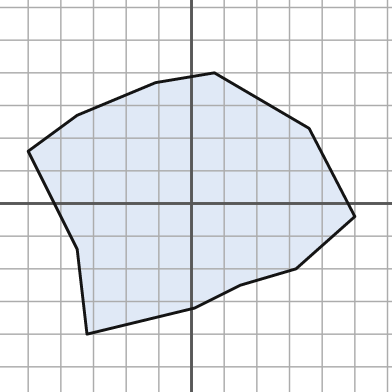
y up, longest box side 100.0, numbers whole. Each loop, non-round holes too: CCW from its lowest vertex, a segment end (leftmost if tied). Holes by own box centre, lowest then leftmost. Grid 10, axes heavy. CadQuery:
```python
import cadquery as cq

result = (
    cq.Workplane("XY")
    .moveTo(-32.0, -40.0)
    .lineTo(1.0, -32.0)
    .lineTo(15.0, -25.0)
    .lineTo(32.0, -20.0)
    .lineTo(50.0, -4.0)
    .lineTo(36.0, 23.0)
    .lineTo(7.0, 40.0)
    .lineTo(-11.0, 37.0)
    .lineTo(-35.0, 27.0)
    .lineTo(-50.0, 16.0)
    .lineTo(-35.0, -14.0)
    .close()
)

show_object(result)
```